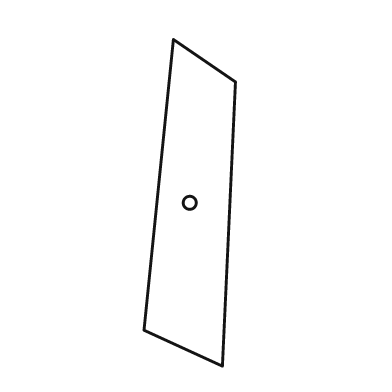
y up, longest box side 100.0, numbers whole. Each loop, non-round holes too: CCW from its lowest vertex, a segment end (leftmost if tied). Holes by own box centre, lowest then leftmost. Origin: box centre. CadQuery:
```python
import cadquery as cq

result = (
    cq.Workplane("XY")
    .moveTo(10.0, -50.0)
    .lineTo(14.0, 37.0)
    .lineTo(-5.0, 50.0)
    .lineTo(-14.0, -39.0)
    .close()
    .moveTo(0.0, 0.0)
    .circle(2.0)
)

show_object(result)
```